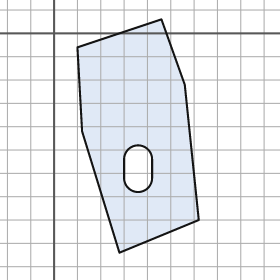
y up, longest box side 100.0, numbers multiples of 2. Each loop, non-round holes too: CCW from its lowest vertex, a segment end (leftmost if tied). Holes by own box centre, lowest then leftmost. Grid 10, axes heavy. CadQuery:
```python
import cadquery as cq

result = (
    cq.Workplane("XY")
    .moveTo(28.0, -94.0)
    .lineTo(62.0, -80.0)
    .lineTo(56.0, -22.0)
    .lineTo(46.0, 6.0)
    .lineTo(10.0, -6.0)
    .lineTo(12.0, -42.0)
    .close()
    .moveTo(30.0, -62.0)
    .threePointArc((36.0, -68.0), (42.0, -62.0))
    .lineTo(42.0, -54.0)
    .threePointArc((36.0, -48.0), (30.0, -54.0))
    .close()
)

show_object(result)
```